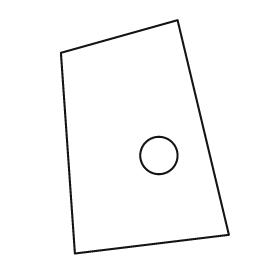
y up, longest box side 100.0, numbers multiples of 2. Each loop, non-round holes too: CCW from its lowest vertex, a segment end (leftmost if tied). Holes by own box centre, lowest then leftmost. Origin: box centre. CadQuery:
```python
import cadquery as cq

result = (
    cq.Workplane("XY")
    .moveTo(-30.0, -50.0)
    .lineTo(36.0, -42.0)
    .lineTo(14.0, 50.0)
    .lineTo(-36.0, 36.0)
    .close()
    .moveTo(6.0, -8.0)
    .circle(8.0)
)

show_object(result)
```